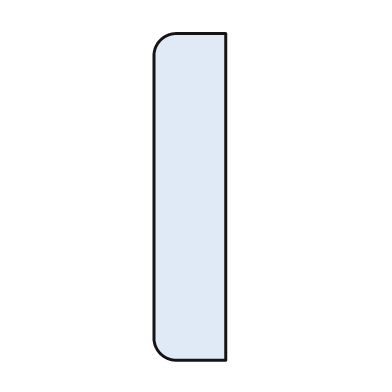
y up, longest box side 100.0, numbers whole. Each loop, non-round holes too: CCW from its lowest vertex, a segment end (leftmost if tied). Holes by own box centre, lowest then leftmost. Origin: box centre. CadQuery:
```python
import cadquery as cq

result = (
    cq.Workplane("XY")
    .moveTo(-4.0, -50.0)
    .lineTo(11.0, -50.0)
    .lineTo(11.0, 50.0)
    .lineTo(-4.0, 50.0)
    .threePointArc((-9.0, 48.0), (-11.0, 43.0))
    .lineTo(-11.0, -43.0)
    .threePointArc((-9.0, -48.0), (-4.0, -50.0))
    .close()
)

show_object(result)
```